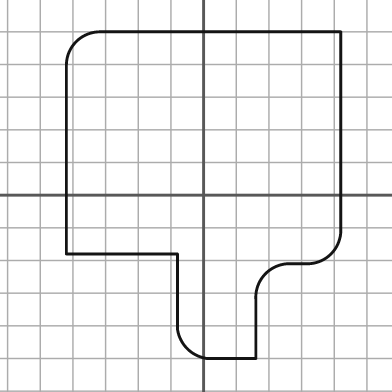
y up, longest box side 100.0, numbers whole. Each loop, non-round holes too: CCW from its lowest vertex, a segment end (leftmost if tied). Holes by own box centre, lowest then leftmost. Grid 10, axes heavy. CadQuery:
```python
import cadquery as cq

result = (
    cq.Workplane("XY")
    .moveTo(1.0, -50.0)
    .lineTo(16.0, -50.0)
    .lineTo(16.0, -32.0)
    .threePointArc((19.0, -24.0), (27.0, -21.0))
    .lineTo(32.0, -21.0)
    .threePointArc((39.0, -18.0), (42.0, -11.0))
    .lineTo(42.0, 50.0)
    .lineTo(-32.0, 50.0)
    .threePointArc((-39.0, 47.0), (-42.0, 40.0))
    .lineTo(-42.0, -18.0)
    .lineTo(-8.0, -18.0)
    .lineTo(-8.0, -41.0)
    .threePointArc((-5.0, -47.0), (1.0, -50.0))
    .close()
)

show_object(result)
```